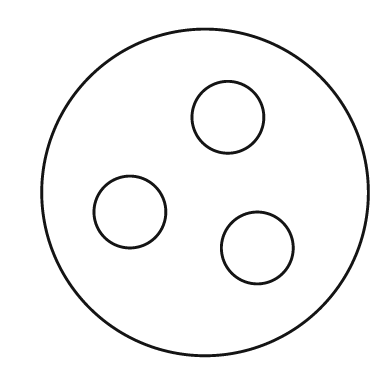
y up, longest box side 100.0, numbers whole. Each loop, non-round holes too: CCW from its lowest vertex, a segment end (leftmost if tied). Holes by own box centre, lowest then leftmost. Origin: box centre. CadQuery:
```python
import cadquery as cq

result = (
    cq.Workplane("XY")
    .moveTo(0.0, 0.0)
    .circle(50.0)
    .moveTo(16.0, -17.0)
    .circle(11.0)
    .moveTo(-23.0, -6.0)
    .circle(11.0)
    .moveTo(7.0, 23.0)
    .circle(11.0)
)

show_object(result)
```